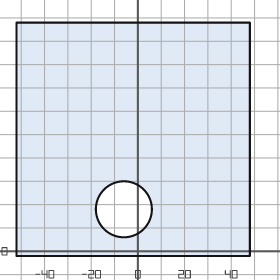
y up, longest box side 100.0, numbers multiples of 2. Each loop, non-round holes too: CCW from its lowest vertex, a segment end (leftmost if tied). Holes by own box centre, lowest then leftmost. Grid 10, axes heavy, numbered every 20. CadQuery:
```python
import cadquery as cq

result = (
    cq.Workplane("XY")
    .moveTo(-52.0, -2.0)
    .lineTo(48.0, -2.0)
    .lineTo(48.0, 98.0)
    .lineTo(-52.0, 98.0)
    .close()
    .moveTo(-6.0, 18.0)
    .circle(12.0)
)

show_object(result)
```